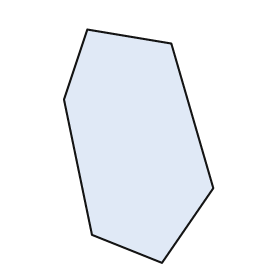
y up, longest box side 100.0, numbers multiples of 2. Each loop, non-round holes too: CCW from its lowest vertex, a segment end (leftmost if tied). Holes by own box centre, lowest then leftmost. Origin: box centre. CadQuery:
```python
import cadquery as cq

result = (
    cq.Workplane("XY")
    .moveTo(10.0, -50.0)
    .lineTo(32.0, -18.0)
    .lineTo(14.0, 44.0)
    .lineTo(-22.0, 50.0)
    .lineTo(-32.0, 20.0)
    .lineTo(-20.0, -38.0)
    .close()
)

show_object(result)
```